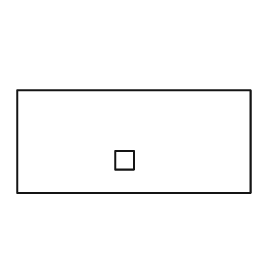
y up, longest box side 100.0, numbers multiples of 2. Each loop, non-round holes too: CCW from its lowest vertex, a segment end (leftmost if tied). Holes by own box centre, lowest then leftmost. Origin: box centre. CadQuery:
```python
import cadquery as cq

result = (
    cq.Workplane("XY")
    .moveTo(-50.0, -22.0)
    .lineTo(50.0, -22.0)
    .lineTo(50.0, 22.0)
    .lineTo(-50.0, 22.0)
    .close()
    .moveTo(-8.0, -12.0)
    .lineTo(0.0, -12.0)
    .lineTo(0.0, -4.0)
    .lineTo(-8.0, -4.0)
    .close()
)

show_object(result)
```